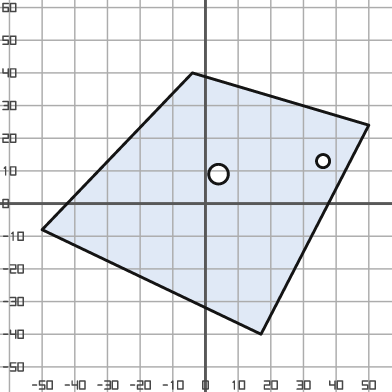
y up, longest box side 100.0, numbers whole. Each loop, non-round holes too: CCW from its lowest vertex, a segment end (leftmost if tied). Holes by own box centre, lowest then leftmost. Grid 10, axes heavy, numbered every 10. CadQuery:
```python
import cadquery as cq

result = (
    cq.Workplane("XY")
    .moveTo(17.0, -40.0)
    .lineTo(50.0, 24.0)
    .lineTo(-4.0, 40.0)
    .lineTo(-50.0, -8.0)
    .close()
    .moveTo(4.0, 9.0)
    .circle(3.0)
    .moveTo(36.0, 13.0)
    .circle(2.0)
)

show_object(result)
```